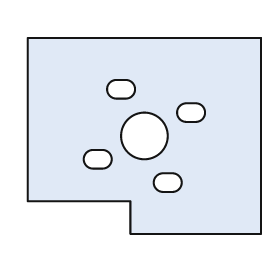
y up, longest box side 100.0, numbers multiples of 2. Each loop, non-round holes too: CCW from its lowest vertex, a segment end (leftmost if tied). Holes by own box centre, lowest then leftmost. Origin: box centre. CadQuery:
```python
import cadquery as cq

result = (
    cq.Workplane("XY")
    .moveTo(-6.0, -42.0)
    .lineTo(50.0, -42.0)
    .lineTo(50.0, 42.0)
    .lineTo(-50.0, 42.0)
    .lineTo(-50.0, -28.0)
    .lineTo(-6.0, -28.0)
    .close()
    .moveTo(8.0, -24.0)
    .lineTo(12.0, -24.0)
    .threePointArc((16.0, -20.0), (12.0, -16.0))
    .lineTo(8.0, -16.0)
    .threePointArc((4.0, -20.0), (8.0, -24.0))
    .close()
    .moveTo(-22.0, -14.0)
    .lineTo(-18.0, -14.0)
    .threePointArc((-14.0, -10.0), (-18.0, -6.0))
    .lineTo(-22.0, -6.0)
    .threePointArc((-26.0, -10.0), (-22.0, -14.0))
    .close()
    .moveTo(0.0, 0.0)
    .circle(10.0)
    .moveTo(18.0, 6.0)
    .lineTo(22.0, 6.0)
    .threePointArc((26.0, 10.0), (22.0, 14.0))
    .lineTo(18.0, 14.0)
    .threePointArc((14.0, 10.0), (18.0, 6.0))
    .close()
    .moveTo(-12.0, 16.0)
    .lineTo(-8.0, 16.0)
    .threePointArc((-4.0, 20.0), (-8.0, 24.0))
    .lineTo(-12.0, 24.0)
    .threePointArc((-16.0, 20.0), (-12.0, 16.0))
    .close()
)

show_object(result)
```